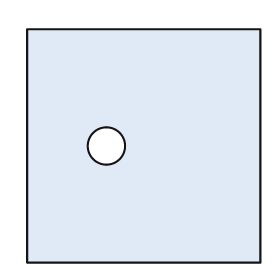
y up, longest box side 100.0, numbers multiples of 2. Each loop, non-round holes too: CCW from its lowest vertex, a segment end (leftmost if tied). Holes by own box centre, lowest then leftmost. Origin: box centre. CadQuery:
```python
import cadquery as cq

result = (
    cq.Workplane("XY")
    .moveTo(-50.0, -50.0)
    .lineTo(50.0, -50.0)
    .lineTo(50.0, 50.0)
    .lineTo(-50.0, 50.0)
    .close()
    .moveTo(-16.0, 0.0)
    .circle(8.0)
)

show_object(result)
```